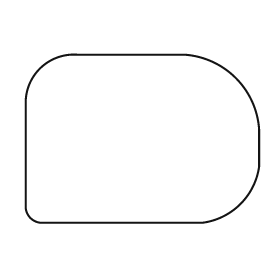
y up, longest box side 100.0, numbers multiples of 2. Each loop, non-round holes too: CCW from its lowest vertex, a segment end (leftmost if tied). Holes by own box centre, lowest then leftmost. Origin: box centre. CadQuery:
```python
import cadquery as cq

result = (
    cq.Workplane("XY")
    .moveTo(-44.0, -36.0)
    .lineTo(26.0, -36.0)
    .threePointArc((42.0, -28.0), (50.0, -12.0))
    .lineTo(50.0, 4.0)
    .threePointArc((40.0, 26.0), (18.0, 36.0))
    .lineTo(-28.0, 36.0)
    .threePointArc((-44.0, 30.0), (-50.0, 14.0))
    .lineTo(-50.0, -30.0)
    .threePointArc((-48.0, -34.0), (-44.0, -36.0))
    .close()
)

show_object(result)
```